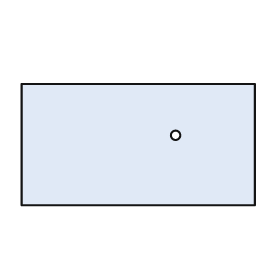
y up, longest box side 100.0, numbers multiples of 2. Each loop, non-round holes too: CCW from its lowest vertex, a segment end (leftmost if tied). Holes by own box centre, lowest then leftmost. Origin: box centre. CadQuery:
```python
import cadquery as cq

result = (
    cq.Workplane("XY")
    .moveTo(-50.0, -26.0)
    .lineTo(50.0, -26.0)
    .lineTo(50.0, 26.0)
    .lineTo(-50.0, 26.0)
    .close()
    .moveTo(16.0, 4.0)
    .circle(2.0)
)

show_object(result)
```